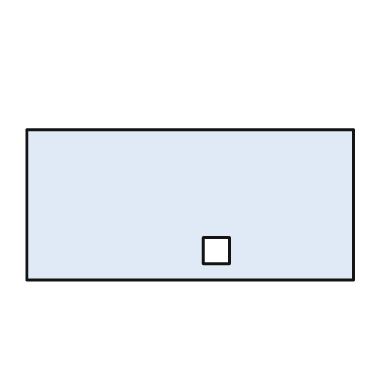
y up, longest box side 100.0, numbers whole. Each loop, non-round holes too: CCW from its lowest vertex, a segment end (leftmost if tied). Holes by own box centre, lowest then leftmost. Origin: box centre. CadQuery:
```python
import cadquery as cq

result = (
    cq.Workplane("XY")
    .moveTo(-50.0, -23.0)
    .lineTo(50.0, -23.0)
    .lineTo(50.0, 23.0)
    .lineTo(-50.0, 23.0)
    .close()
    .moveTo(4.0, -18.0)
    .lineTo(12.0, -18.0)
    .lineTo(12.0, -10.0)
    .lineTo(4.0, -10.0)
    .close()
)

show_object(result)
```